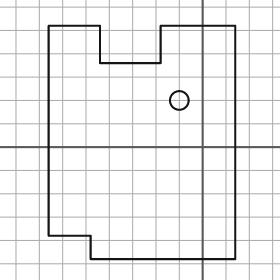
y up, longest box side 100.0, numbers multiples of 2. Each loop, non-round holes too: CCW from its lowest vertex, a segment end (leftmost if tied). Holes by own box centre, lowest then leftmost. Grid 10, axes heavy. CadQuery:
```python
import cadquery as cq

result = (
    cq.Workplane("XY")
    .moveTo(-48.0, -48.0)
    .lineTo(14.0, -48.0)
    .lineTo(14.0, 52.0)
    .lineTo(-18.0, 52.0)
    .lineTo(-18.0, 36.0)
    .lineTo(-44.0, 36.0)
    .lineTo(-44.0, 52.0)
    .lineTo(-66.0, 52.0)
    .lineTo(-66.0, -38.0)
    .lineTo(-48.0, -38.0)
    .close()
    .moveTo(-10.0, 20.0)
    .circle(4.0)
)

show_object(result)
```